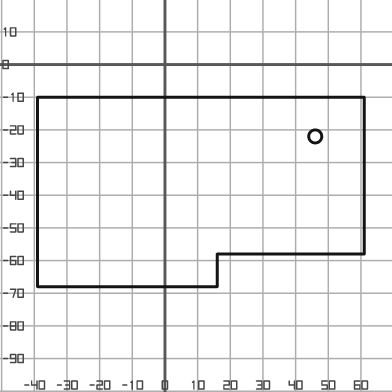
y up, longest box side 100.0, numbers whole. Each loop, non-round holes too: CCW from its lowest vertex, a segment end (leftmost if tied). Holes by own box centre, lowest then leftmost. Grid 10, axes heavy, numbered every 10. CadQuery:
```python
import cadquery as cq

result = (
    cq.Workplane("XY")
    .moveTo(-39.0, -68.0)
    .lineTo(16.0, -68.0)
    .lineTo(16.0, -58.0)
    .lineTo(61.0, -58.0)
    .lineTo(61.0, -10.0)
    .lineTo(-39.0, -10.0)
    .close()
    .moveTo(46.0, -22.0)
    .circle(2.0)
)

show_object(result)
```